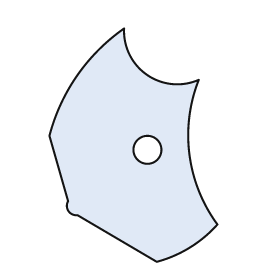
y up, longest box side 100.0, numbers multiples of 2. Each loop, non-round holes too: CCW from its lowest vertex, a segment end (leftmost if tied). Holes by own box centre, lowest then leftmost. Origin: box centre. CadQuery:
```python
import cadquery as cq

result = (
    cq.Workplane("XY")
    .moveTo(10.0, -50.0)
    .threePointArc((24.0, -44.0), (36.0, -34.0))
    .threePointArc((24.0, -4.0), (28.0, 28.0))
    .threePointArc((6.0, 30.0), (-4.0, 50.0))
    .threePointArc((-24.0, 30.0), (-36.0, 4.0))
    .lineTo(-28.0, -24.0)
    .threePointArc((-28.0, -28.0), (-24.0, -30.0))
    .close()
    .moveTo(6.0, -2.0)
    .circle(6.0)
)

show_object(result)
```